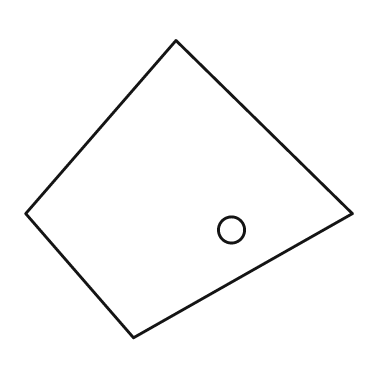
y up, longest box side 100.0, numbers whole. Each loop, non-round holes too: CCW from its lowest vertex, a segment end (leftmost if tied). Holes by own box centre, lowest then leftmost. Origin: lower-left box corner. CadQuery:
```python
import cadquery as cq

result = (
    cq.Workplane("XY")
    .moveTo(33.0, 0.0)
    .lineTo(100.0, 38.0)
    .lineTo(46.0, 91.0)
    .lineTo(0.0, 38.0)
    .close()
    .moveTo(63.0, 33.0)
    .circle(4.0)
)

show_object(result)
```